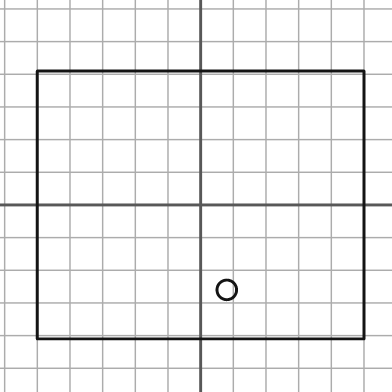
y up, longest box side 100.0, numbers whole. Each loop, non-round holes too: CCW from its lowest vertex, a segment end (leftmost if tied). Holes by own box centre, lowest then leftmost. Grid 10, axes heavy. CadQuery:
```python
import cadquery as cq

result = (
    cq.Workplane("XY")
    .moveTo(-50.0, -41.0)
    .lineTo(50.0, -41.0)
    .lineTo(50.0, 41.0)
    .lineTo(-50.0, 41.0)
    .close()
    .moveTo(8.0, -26.0)
    .circle(3.0)
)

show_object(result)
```